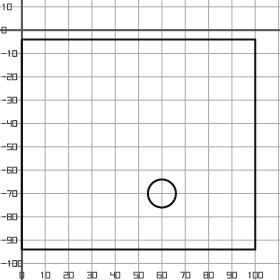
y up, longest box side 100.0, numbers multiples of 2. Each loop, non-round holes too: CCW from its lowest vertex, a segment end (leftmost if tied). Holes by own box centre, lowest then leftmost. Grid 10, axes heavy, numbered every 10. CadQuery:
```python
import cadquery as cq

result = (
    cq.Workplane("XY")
    .moveTo(0.0, -94.0)
    .lineTo(100.0, -94.0)
    .lineTo(100.0, -4.0)
    .lineTo(0.0, -4.0)
    .close()
    .moveTo(60.0, -70.0)
    .circle(6.0)
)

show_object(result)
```